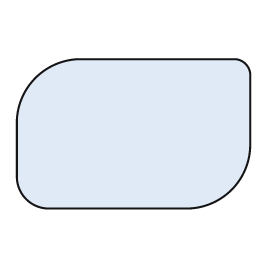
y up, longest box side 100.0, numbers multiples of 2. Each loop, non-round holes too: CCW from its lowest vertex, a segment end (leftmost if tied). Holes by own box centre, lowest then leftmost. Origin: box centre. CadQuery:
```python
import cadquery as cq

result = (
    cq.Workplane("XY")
    .moveTo(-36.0, -32.0)
    .lineTo(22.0, -32.0)
    .threePointArc((42.0, -24.0), (50.0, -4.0))
    .lineTo(50.0, 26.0)
    .threePointArc((48.0, 30.0), (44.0, 32.0))
    .lineTo(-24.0, 32.0)
    .threePointArc((-42.0, 24.0), (-50.0, 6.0))
    .lineTo(-50.0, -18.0)
    .threePointArc((-46.0, -28.0), (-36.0, -32.0))
    .close()
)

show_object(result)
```